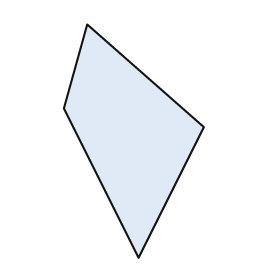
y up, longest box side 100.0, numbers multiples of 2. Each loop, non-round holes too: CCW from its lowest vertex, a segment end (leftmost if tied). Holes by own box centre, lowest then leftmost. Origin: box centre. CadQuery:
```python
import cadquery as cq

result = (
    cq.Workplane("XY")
    .moveTo(2.0, -50.0)
    .lineTo(30.0, 6.0)
    .lineTo(-20.0, 50.0)
    .lineTo(-30.0, 14.0)
    .close()
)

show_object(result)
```